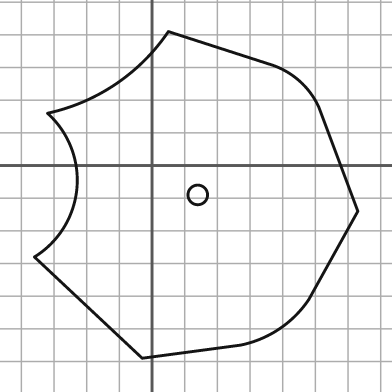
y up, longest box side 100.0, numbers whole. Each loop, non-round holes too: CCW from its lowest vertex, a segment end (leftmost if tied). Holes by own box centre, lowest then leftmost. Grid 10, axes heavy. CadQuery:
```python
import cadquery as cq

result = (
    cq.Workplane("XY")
    .moveTo(-3.0, -59.0)
    .lineTo(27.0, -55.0)
    .threePointArc((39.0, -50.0), (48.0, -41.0))
    .lineTo(63.0, -14.0)
    .lineTo(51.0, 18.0)
    .threePointArc((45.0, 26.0), (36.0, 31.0))
    .lineTo(5.0, 41.0)
    .threePointArc((-11.0, 25.0), (-32.0, 16.0))
    .threePointArc((-23.0, -7.0), (-36.0, -28.0))
    .close()
    .moveTo(14.0, -9.0)
    .circle(3.0)
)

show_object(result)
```